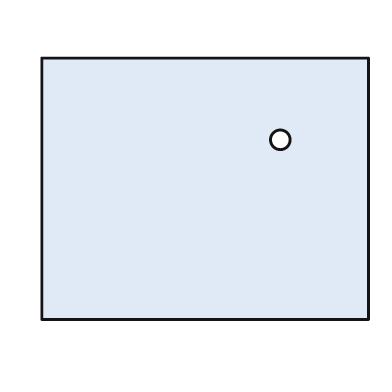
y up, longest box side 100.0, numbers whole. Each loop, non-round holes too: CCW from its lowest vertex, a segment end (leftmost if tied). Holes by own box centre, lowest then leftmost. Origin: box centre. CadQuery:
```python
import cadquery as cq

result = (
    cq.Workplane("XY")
    .moveTo(-50.0, -40.0)
    .lineTo(50.0, -40.0)
    .lineTo(50.0, 40.0)
    .lineTo(-50.0, 40.0)
    .close()
    .moveTo(23.0, 15.0)
    .circle(3.0)
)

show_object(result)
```